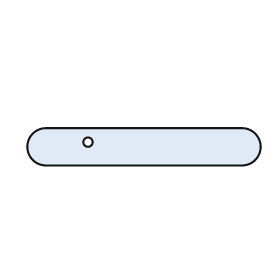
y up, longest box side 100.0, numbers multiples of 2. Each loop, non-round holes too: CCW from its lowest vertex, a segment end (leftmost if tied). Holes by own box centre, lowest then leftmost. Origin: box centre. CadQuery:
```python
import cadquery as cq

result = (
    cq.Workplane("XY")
    .moveTo(-42.0, -8.0)
    .lineTo(42.0, -8.0)
    .threePointArc((50.0, 0.0), (42.0, 8.0))
    .lineTo(-42.0, 8.0)
    .threePointArc((-50.0, 0.0), (-42.0, -8.0))
    .close()
    .moveTo(-24.0, 2.0)
    .circle(2.0)
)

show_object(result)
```